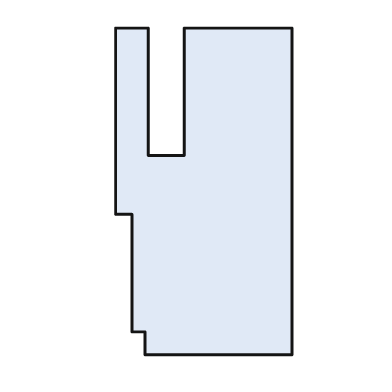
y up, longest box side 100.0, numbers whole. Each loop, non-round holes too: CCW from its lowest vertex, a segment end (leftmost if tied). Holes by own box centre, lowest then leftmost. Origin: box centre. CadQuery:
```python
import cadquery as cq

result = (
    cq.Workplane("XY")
    .moveTo(-18.0, -50.0)
    .lineTo(27.0, -50.0)
    .lineTo(27.0, 50.0)
    .lineTo(-6.0, 50.0)
    .lineTo(-6.0, 11.0)
    .lineTo(-17.0, 11.0)
    .lineTo(-17.0, 50.0)
    .lineTo(-27.0, 50.0)
    .lineTo(-27.0, -7.0)
    .lineTo(-22.0, -7.0)
    .lineTo(-22.0, -43.0)
    .lineTo(-18.0, -43.0)
    .close()
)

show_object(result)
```